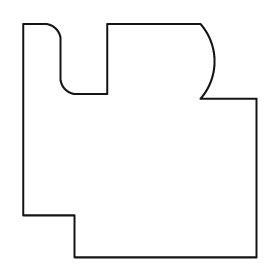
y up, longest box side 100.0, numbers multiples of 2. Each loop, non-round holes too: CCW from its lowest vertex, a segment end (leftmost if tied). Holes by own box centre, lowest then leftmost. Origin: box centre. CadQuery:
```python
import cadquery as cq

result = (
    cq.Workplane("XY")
    .moveTo(-28.0, -50.0)
    .lineTo(50.0, -50.0)
    .lineTo(50.0, 18.0)
    .lineTo(26.0, 18.0)
    .threePointArc((32.0, 34.0), (26.0, 50.0))
    .lineTo(-14.0, 50.0)
    .lineTo(-14.0, 20.0)
    .lineTo(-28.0, 20.0)
    .threePointArc((-32.0, 22.0), (-34.0, 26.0))
    .lineTo(-34.0, 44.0)
    .threePointArc((-36.0, 48.0), (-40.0, 50.0))
    .lineTo(-50.0, 50.0)
    .lineTo(-50.0, -32.0)
    .lineTo(-28.0, -32.0)
    .close()
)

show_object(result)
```